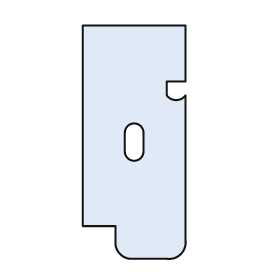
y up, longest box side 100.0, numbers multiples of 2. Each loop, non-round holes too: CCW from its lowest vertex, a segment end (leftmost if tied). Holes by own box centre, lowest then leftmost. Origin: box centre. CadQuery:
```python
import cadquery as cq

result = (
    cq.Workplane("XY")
    .moveTo(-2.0, -50.0)
    .lineTo(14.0, -50.0)
    .threePointArc((20.0, -48.0), (22.0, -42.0))
    .lineTo(22.0, 20.0)
    .threePointArc((18.0, 18.0), (14.0, 20.0))
    .lineTo(14.0, 26.0)
    .lineTo(22.0, 26.0)
    .lineTo(22.0, 50.0)
    .lineTo(-22.0, 50.0)
    .lineTo(-22.0, -36.0)
    .lineTo(-8.0, -36.0)
    .lineTo(-8.0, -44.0)
    .threePointArc((-6.0, -48.0), (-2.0, -50.0))
    .close()
    .moveTo(-4.0, -4.0)
    .threePointArc((0.0, -8.0), (4.0, -4.0))
    .lineTo(4.0, 4.0)
    .threePointArc((0.0, 8.0), (-4.0, 4.0))
    .close()
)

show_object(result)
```